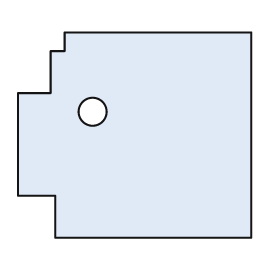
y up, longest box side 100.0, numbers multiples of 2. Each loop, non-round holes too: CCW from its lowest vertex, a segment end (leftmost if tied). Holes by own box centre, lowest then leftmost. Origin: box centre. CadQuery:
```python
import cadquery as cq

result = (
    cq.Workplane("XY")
    .moveTo(-34.0, -44.0)
    .lineTo(50.0, -44.0)
    .lineTo(50.0, 44.0)
    .lineTo(-30.0, 44.0)
    .lineTo(-30.0, 36.0)
    .lineTo(-36.0, 36.0)
    .lineTo(-36.0, 18.0)
    .lineTo(-50.0, 18.0)
    .lineTo(-50.0, -26.0)
    .lineTo(-34.0, -26.0)
    .close()
    .moveTo(-18.0, 10.0)
    .circle(6.0)
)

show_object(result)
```